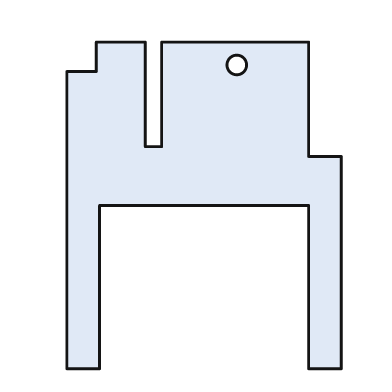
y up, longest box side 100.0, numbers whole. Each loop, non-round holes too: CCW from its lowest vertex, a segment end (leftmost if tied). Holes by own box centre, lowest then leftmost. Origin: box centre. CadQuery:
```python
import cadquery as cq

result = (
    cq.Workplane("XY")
    .moveTo(-42.0, -50.0)
    .lineTo(-32.0, -50.0)
    .lineTo(-32.0, 0.0)
    .lineTo(32.0, 0.0)
    .lineTo(32.0, -50.0)
    .lineTo(42.0, -50.0)
    .lineTo(42.0, 15.0)
    .lineTo(32.0, 15.0)
    .lineTo(32.0, 50.0)
    .lineTo(-13.0, 50.0)
    .lineTo(-13.0, 18.0)
    .lineTo(-18.0, 18.0)
    .lineTo(-18.0, 50.0)
    .lineTo(-33.0, 50.0)
    .lineTo(-33.0, 41.0)
    .lineTo(-42.0, 41.0)
    .close()
    .moveTo(10.0, 43.0)
    .circle(3.0)
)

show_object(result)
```